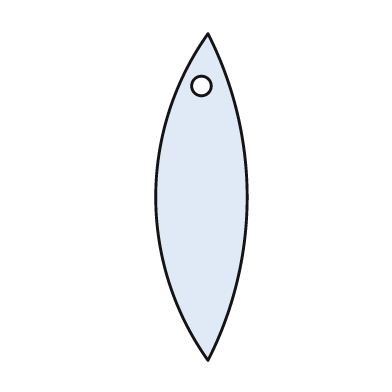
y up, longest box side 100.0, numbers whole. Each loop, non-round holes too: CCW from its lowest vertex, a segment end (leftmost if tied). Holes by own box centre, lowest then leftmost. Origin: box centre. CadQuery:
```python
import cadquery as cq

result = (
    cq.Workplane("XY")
    .moveTo(2.0, -50.0)
    .threePointArc((14.0, 0.0), (2.0, 50.0))
    .threePointArc((-14.0, 0.0), (2.0, -50.0))
    .close()
    .moveTo(0.0, 34.0)
    .circle(3.0)
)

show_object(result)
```